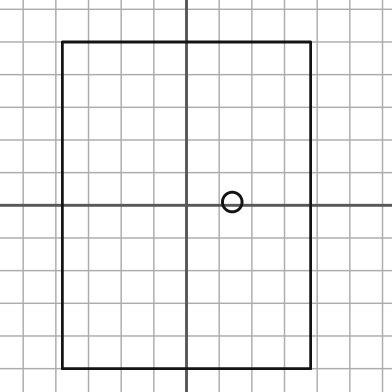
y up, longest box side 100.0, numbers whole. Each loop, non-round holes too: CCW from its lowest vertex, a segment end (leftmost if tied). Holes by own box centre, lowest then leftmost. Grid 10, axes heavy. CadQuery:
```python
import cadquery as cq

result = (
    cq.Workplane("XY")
    .moveTo(-38.0, -50.0)
    .lineTo(38.0, -50.0)
    .lineTo(38.0, 50.0)
    .lineTo(-38.0, 50.0)
    .close()
    .moveTo(14.0, 1.0)
    .circle(3.0)
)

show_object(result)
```